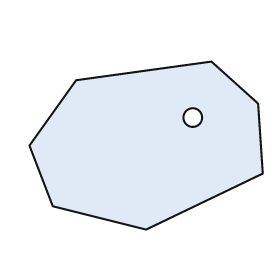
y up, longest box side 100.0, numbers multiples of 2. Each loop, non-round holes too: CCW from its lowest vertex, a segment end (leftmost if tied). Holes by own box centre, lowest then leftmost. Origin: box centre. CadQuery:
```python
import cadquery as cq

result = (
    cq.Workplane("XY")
    .moveTo(0.0, -36.0)
    .lineTo(50.0, -12.0)
    .lineTo(48.0, 18.0)
    .lineTo(28.0, 36.0)
    .lineTo(-30.0, 28.0)
    .lineTo(-50.0, 0.0)
    .lineTo(-40.0, -26.0)
    .close()
    .moveTo(20.0, 12.0)
    .circle(4.0)
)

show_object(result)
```